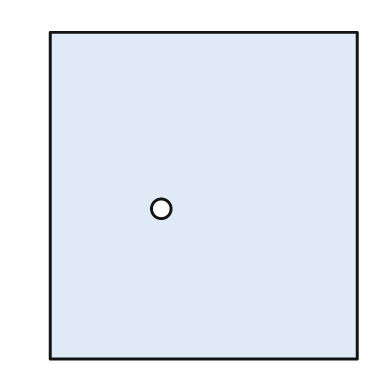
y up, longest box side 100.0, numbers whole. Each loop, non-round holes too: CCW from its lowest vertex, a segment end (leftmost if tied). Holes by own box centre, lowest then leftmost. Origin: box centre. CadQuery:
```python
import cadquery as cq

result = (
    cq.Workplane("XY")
    .moveTo(-47.0, -50.0)
    .lineTo(47.0, -50.0)
    .lineTo(47.0, 50.0)
    .lineTo(-47.0, 50.0)
    .close()
    .moveTo(-13.0, -4.0)
    .circle(3.0)
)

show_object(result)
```